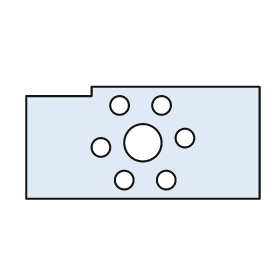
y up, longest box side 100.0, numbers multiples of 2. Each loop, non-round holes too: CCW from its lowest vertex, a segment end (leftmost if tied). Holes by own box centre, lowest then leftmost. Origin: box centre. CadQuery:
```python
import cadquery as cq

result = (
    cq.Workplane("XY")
    .moveTo(-50.0, -24.0)
    .lineTo(50.0, -24.0)
    .lineTo(50.0, 24.0)
    .lineTo(-22.0, 24.0)
    .lineTo(-22.0, 20.0)
    .lineTo(-50.0, 20.0)
    .close()
    .moveTo(-8.0, -16.0)
    .circle(4.0)
    .moveTo(10.0, -16.0)
    .circle(4.0)
    .moveTo(-18.0, -2.0)
    .circle(4.0)
    .moveTo(0.0, 0.0)
    .circle(8.0)
    .moveTo(18.0, 2.0)
    .circle(4.0)
    .moveTo(-10.0, 16.0)
    .circle(4.0)
    .moveTo(8.0, 16.0)
    .circle(4.0)
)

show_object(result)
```